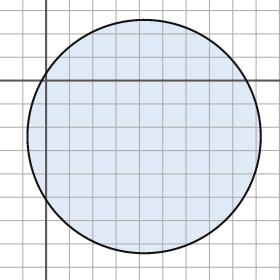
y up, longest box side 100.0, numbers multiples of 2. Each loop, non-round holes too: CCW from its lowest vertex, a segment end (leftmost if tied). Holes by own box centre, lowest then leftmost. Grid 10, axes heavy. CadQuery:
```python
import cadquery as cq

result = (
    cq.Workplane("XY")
    .moveTo(42.0, -24.0)
    .circle(50.0)
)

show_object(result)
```